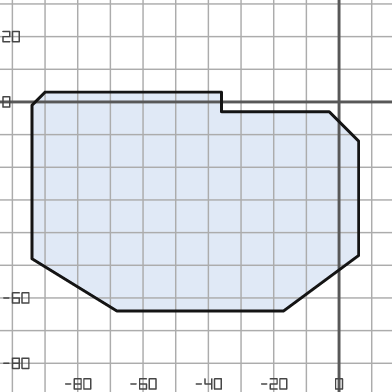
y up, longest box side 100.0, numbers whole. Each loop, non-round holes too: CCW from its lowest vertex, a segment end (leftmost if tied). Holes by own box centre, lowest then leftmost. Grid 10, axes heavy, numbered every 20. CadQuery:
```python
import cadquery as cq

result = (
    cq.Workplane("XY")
    .moveTo(-68.0, -64.0)
    .lineTo(-17.0, -64.0)
    .lineTo(6.0, -47.0)
    .lineTo(6.0, -12.0)
    .lineTo(-3.0, -3.0)
    .lineTo(-36.0, -3.0)
    .lineTo(-36.0, 3.0)
    .lineTo(-90.0, 3.0)
    .lineTo(-94.0, -1.0)
    .lineTo(-94.0, -48.0)
    .close()
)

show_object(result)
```